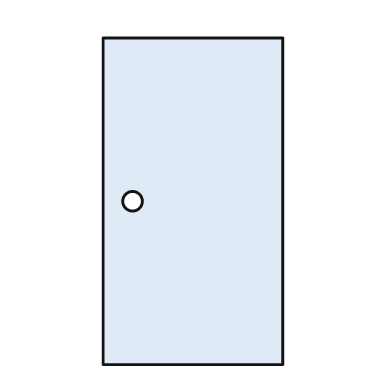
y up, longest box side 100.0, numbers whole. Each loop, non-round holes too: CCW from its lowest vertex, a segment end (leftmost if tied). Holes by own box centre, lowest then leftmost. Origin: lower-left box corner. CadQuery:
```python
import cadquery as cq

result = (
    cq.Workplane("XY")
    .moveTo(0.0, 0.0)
    .lineTo(55.0, 0.0)
    .lineTo(55.0, 100.0)
    .lineTo(0.0, 100.0)
    .close()
    .moveTo(9.0, 50.0)
    .circle(3.0)
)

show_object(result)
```